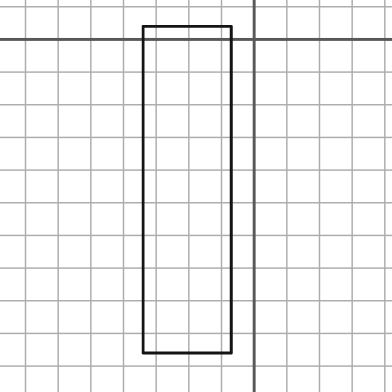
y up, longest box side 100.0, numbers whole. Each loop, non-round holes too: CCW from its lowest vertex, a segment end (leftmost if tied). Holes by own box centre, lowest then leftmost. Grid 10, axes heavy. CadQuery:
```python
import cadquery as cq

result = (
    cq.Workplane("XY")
    .moveTo(-34.0, -96.0)
    .lineTo(-7.0, -96.0)
    .lineTo(-7.0, 4.0)
    .lineTo(-34.0, 4.0)
    .close()
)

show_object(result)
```